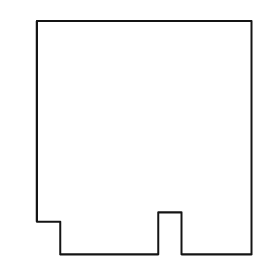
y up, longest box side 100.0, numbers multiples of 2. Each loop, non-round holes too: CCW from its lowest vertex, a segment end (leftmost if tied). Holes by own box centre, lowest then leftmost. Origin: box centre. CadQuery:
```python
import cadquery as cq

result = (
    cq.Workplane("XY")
    .moveTo(-36.0, -50.0)
    .lineTo(6.0, -50.0)
    .lineTo(6.0, -32.0)
    .lineTo(16.0, -32.0)
    .lineTo(16.0, -50.0)
    .lineTo(46.0, -50.0)
    .lineTo(46.0, 50.0)
    .lineTo(-46.0, 50.0)
    .lineTo(-46.0, -36.0)
    .lineTo(-36.0, -36.0)
    .close()
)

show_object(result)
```